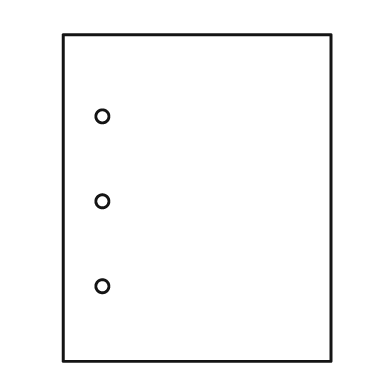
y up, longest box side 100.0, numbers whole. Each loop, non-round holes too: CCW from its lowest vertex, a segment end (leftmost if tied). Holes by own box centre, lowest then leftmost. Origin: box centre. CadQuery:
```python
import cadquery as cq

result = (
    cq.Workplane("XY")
    .moveTo(-41.0, -50.0)
    .lineTo(41.0, -50.0)
    .lineTo(41.0, 50.0)
    .lineTo(-41.0, 50.0)
    .close()
    .moveTo(-29.0, -27.0)
    .circle(2.0)
    .moveTo(-29.0, -1.0)
    .circle(2.0)
    .moveTo(-29.0, 25.0)
    .circle(2.0)
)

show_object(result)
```